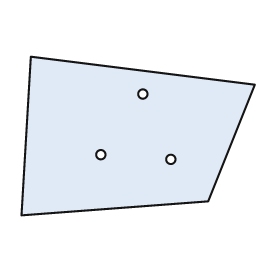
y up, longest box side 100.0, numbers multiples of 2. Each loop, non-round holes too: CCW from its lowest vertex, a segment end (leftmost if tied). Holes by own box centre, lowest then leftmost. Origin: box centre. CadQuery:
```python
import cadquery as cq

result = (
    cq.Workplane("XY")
    .moveTo(-50.0, -34.0)
    .lineTo(30.0, -28.0)
    .lineTo(50.0, 22.0)
    .lineTo(-46.0, 34.0)
    .close()
    .moveTo(14.0, -10.0)
    .circle(2.0)
    .moveTo(-16.0, -8.0)
    .circle(2.0)
    .moveTo(2.0, 18.0)
    .circle(2.0)
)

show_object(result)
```